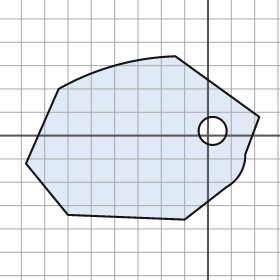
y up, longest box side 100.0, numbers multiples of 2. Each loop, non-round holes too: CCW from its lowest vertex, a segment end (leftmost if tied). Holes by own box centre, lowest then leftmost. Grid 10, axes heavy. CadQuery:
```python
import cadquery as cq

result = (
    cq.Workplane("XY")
    .moveTo(-10.0, -36.0)
    .lineTo(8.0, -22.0)
    .threePointArc((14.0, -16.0), (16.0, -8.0))
    .lineTo(22.0, 8.0)
    .lineTo(-14.0, 34.0)
    .threePointArc((-40.0, 30.0), (-64.0, 20.0))
    .lineTo(-78.0, -12.0)
    .lineTo(-60.0, -34.0)
    .close()
    .moveTo(2.0, 2.0)
    .circle(6.0)
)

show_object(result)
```